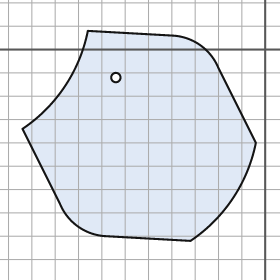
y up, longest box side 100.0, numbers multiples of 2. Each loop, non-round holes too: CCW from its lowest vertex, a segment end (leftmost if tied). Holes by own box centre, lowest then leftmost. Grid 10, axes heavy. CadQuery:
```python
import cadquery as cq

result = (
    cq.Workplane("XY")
    .moveTo(-32.0, -82.0)
    .threePointArc((-14.0, -64.0), (-4.0, -40.0))
    .lineTo(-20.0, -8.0)
    .threePointArc((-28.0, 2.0), (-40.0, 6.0))
    .lineTo(-76.0, 8.0)
    .threePointArc((-86.0, -16.0), (-104.0, -34.0))
    .lineTo(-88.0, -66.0)
    .threePointArc((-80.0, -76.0), (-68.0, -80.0))
    .close()
    .moveTo(-64.0, -12.0)
    .circle(2.0)
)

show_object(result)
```